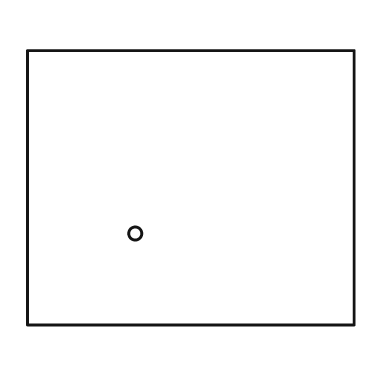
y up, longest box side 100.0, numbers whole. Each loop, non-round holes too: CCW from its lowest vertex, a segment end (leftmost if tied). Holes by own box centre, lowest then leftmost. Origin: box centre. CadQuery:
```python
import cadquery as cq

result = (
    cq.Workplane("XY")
    .moveTo(-50.0, -42.0)
    .lineTo(50.0, -42.0)
    .lineTo(50.0, 42.0)
    .lineTo(-50.0, 42.0)
    .close()
    .moveTo(-17.0, -14.0)
    .circle(2.0)
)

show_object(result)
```